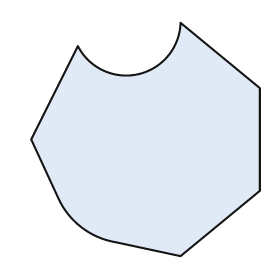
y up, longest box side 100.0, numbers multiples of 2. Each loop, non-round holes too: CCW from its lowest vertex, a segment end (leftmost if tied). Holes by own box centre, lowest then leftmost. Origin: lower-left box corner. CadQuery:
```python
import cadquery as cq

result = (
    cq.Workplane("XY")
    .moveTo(64.0, 0.0)
    .lineTo(98.0, 28.0)
    .lineTo(98.0, 72.0)
    .lineTo(64.0, 100.0)
    .threePointArc((46.0, 78.0), (20.0, 90.0))
    .lineTo(0.0, 50.0)
    .lineTo(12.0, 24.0)
    .threePointArc((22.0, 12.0), (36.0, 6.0))
    .close()
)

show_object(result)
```